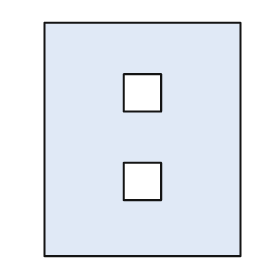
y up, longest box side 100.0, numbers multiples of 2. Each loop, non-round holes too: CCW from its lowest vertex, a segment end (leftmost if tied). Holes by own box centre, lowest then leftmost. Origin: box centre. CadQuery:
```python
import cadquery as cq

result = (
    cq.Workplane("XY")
    .moveTo(-42.0, -50.0)
    .lineTo(42.0, -50.0)
    .lineTo(42.0, 50.0)
    .lineTo(-42.0, 50.0)
    .close()
    .moveTo(-8.0, -26.0)
    .lineTo(8.0, -26.0)
    .lineTo(8.0, -10.0)
    .lineTo(-8.0, -10.0)
    .close()
    .moveTo(-8.0, 12.0)
    .lineTo(8.0, 12.0)
    .lineTo(8.0, 28.0)
    .lineTo(-8.0, 28.0)
    .close()
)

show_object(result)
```